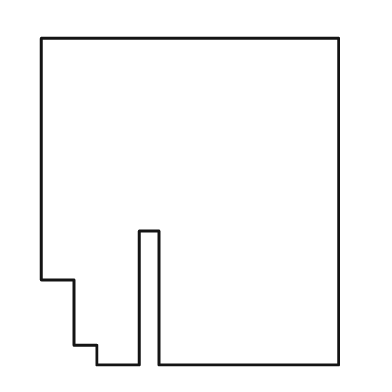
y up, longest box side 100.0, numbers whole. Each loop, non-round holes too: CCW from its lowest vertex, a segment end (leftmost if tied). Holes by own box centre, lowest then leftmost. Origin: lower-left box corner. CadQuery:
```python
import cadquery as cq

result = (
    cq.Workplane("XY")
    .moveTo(17.0, 0.0)
    .lineTo(30.0, 0.0)
    .lineTo(30.0, 41.0)
    .lineTo(36.0, 41.0)
    .lineTo(36.0, 0.0)
    .lineTo(91.0, 0.0)
    .lineTo(91.0, 100.0)
    .lineTo(0.0, 100.0)
    .lineTo(0.0, 26.0)
    .lineTo(10.0, 26.0)
    .lineTo(10.0, 6.0)
    .lineTo(17.0, 6.0)
    .close()
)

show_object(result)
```